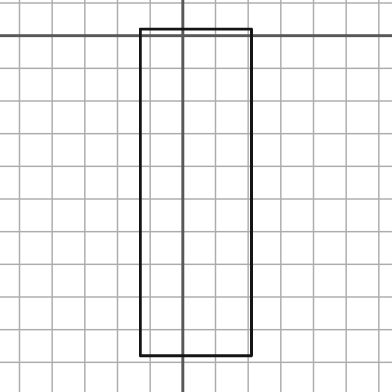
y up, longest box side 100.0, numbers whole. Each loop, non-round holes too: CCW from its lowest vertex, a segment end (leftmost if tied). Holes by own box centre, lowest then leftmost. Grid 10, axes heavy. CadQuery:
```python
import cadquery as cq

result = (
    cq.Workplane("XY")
    .moveTo(-13.0, -98.0)
    .lineTo(21.0, -98.0)
    .lineTo(21.0, 2.0)
    .lineTo(-13.0, 2.0)
    .close()
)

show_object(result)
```